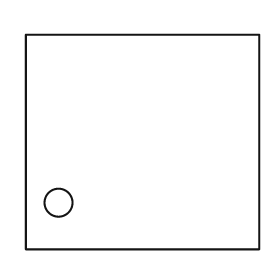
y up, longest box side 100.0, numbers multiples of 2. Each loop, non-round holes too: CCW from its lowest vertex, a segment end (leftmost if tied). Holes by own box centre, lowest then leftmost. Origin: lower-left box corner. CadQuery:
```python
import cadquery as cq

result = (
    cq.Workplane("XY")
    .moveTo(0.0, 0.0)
    .lineTo(100.0, 0.0)
    .lineTo(100.0, 92.0)
    .lineTo(0.0, 92.0)
    .close()
    .moveTo(14.0, 20.0)
    .circle(6.0)
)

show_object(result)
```